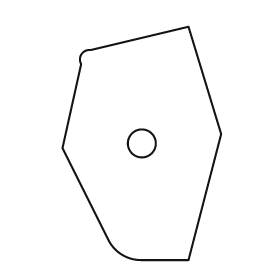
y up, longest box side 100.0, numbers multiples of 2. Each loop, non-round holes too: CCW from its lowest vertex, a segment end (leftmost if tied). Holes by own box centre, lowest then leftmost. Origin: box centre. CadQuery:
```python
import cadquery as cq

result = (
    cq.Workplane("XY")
    .moveTo(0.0, -50.0)
    .lineTo(20.0, -50.0)
    .lineTo(34.0, 4.0)
    .lineTo(20.0, 50.0)
    .lineTo(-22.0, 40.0)
    .threePointArc((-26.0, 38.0), (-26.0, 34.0))
    .lineTo(-34.0, -2.0)
    .lineTo(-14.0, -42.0)
    .threePointArc((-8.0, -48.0), (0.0, -50.0))
    .close()
    .moveTo(0.0, 0.0)
    .circle(6.0)
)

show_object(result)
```